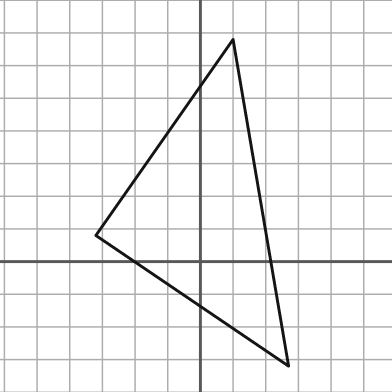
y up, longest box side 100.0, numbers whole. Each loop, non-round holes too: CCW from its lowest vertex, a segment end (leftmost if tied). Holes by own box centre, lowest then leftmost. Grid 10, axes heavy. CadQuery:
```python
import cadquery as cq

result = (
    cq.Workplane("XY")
    .moveTo(27.0, -32.0)
    .lineTo(10.0, 68.0)
    .lineTo(-32.0, 8.0)
    .close()
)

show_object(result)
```